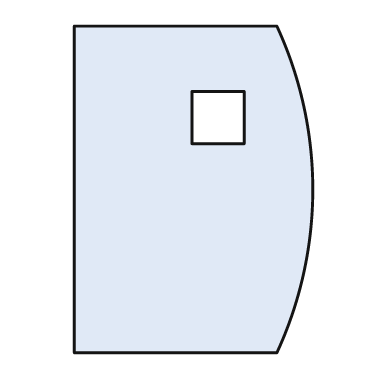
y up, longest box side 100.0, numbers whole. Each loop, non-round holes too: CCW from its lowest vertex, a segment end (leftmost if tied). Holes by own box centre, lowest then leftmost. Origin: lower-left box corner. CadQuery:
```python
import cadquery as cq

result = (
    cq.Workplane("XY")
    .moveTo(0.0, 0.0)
    .lineTo(62.0, 0.0)
    .threePointArc((73.0, 50.0), (62.0, 100.0))
    .lineTo(0.0, 100.0)
    .close()
    .moveTo(36.0, 64.0)
    .lineTo(52.0, 64.0)
    .lineTo(52.0, 80.0)
    .lineTo(36.0, 80.0)
    .close()
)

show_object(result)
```